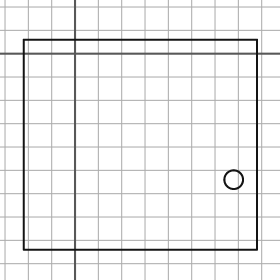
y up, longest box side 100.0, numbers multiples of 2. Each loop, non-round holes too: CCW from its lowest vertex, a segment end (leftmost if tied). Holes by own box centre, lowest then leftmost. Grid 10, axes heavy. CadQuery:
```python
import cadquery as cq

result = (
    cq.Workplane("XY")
    .moveTo(-22.0, -84.0)
    .lineTo(78.0, -84.0)
    .lineTo(78.0, 6.0)
    .lineTo(-22.0, 6.0)
    .close()
    .moveTo(68.0, -54.0)
    .circle(4.0)
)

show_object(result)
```